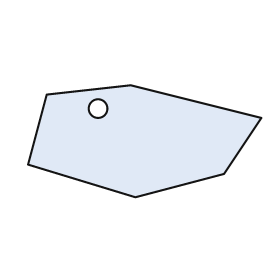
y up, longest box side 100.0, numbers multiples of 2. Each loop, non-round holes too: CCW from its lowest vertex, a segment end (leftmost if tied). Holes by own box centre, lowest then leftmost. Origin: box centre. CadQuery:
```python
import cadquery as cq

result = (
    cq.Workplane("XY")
    .moveTo(-4.0, -24.0)
    .lineTo(34.0, -14.0)
    .lineTo(50.0, 10.0)
    .lineTo(-6.0, 24.0)
    .lineTo(-42.0, 20.0)
    .lineTo(-50.0, -10.0)
    .close()
    .moveTo(-20.0, 14.0)
    .circle(4.0)
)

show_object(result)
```